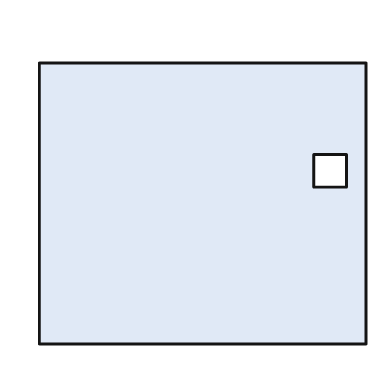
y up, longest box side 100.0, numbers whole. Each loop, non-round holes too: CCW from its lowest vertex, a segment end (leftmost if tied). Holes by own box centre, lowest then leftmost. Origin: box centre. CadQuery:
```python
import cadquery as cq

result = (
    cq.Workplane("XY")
    .moveTo(-50.0, -43.0)
    .lineTo(50.0, -43.0)
    .lineTo(50.0, 43.0)
    .lineTo(-50.0, 43.0)
    .close()
    .moveTo(34.0, 5.0)
    .lineTo(44.0, 5.0)
    .lineTo(44.0, 15.0)
    .lineTo(34.0, 15.0)
    .close()
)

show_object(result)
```